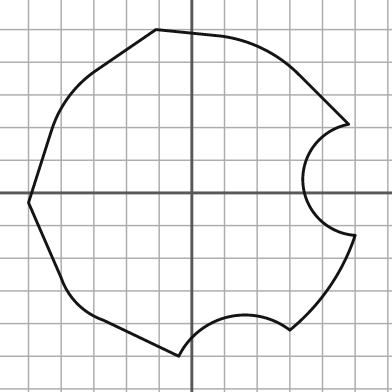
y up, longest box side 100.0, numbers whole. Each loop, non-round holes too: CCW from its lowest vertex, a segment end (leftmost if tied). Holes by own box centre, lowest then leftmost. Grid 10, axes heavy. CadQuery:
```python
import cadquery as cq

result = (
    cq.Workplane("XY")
    .moveTo(-4.0, -50.0)
    .threePointArc((11.0, -38.0), (30.0, -42.0))
    .threePointArc((42.0, -29.0), (50.0, -13.0))
    .threePointArc((34.0, 3.0), (48.0, 21.0))
    .lineTo(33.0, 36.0)
    .threePointArc((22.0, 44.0), (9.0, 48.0))
    .lineTo(-11.0, 50.0)
    .lineTo(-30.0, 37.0)
    .threePointArc((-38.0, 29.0), (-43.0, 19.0))
    .lineTo(-50.0, -3.0)
    .lineTo(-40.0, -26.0)
    .threePointArc((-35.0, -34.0), (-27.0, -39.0))
    .close()
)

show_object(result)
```